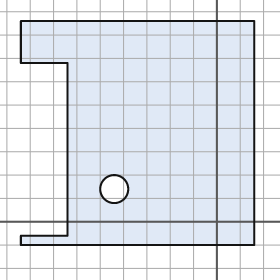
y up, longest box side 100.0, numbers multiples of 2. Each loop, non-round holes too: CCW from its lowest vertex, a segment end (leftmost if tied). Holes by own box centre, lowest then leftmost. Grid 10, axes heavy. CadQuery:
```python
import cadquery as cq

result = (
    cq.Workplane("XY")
    .moveTo(-84.0, -10.0)
    .lineTo(16.0, -10.0)
    .lineTo(16.0, 86.0)
    .lineTo(-84.0, 86.0)
    .lineTo(-84.0, 68.0)
    .lineTo(-64.0, 68.0)
    .lineTo(-64.0, -6.0)
    .lineTo(-84.0, -6.0)
    .close()
    .moveTo(-44.0, 14.0)
    .circle(6.0)
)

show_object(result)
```